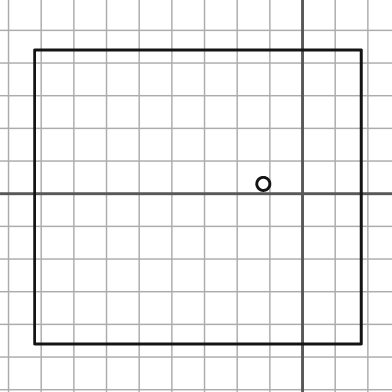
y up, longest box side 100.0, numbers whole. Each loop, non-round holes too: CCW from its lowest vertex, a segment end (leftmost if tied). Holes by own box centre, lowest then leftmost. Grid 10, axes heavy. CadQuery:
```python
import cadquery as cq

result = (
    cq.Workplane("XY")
    .moveTo(-82.0, -46.0)
    .lineTo(18.0, -46.0)
    .lineTo(18.0, 44.0)
    .lineTo(-82.0, 44.0)
    .close()
    .moveTo(-12.0, 3.0)
    .circle(2.0)
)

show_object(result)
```